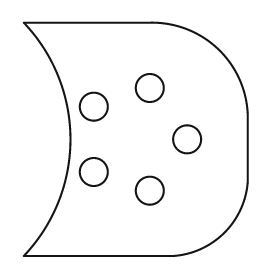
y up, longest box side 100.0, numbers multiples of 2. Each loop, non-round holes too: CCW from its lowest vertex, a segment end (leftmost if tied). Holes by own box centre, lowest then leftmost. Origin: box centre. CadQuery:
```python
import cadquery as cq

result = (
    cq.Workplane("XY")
    .moveTo(-48.0, -50.0)
    .lineTo(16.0, -50.0)
    .threePointArc((38.0, -40.0), (48.0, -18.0))
    .lineTo(48.0, 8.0)
    .threePointArc((36.0, 38.0), (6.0, 50.0))
    .lineTo(-48.0, 50.0)
    .threePointArc((-28.0, 0.0), (-48.0, -50.0))
    .close()
    .moveTo(6.0, -22.0)
    .circle(6.0)
    .moveTo(-18.0, -14.0)
    .circle(6.0)
    .moveTo(22.0, 0.0)
    .circle(6.0)
    .moveTo(-18.0, 14.0)
    .circle(6.0)
    .moveTo(6.0, 22.0)
    .circle(6.0)
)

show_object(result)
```